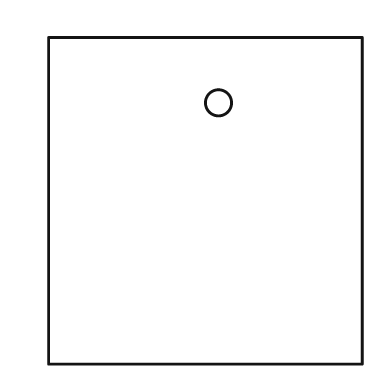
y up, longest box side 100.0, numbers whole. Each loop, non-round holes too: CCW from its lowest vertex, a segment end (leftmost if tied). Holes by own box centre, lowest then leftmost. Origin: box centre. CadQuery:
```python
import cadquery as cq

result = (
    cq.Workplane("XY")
    .moveTo(-48.0, -50.0)
    .lineTo(48.0, -50.0)
    .lineTo(48.0, 50.0)
    .lineTo(-48.0, 50.0)
    .close()
    .moveTo(4.0, 30.0)
    .circle(4.0)
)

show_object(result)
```